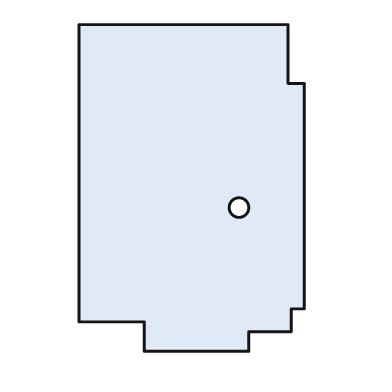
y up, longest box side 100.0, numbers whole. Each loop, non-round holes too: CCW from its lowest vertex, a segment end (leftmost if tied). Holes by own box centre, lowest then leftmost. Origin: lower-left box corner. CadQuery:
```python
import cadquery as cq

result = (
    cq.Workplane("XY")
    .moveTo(20.0, 0.0)
    .lineTo(52.0, 0.0)
    .lineTo(52.0, 6.0)
    .lineTo(65.0, 6.0)
    .lineTo(65.0, 13.0)
    .lineTo(69.0, 13.0)
    .lineTo(69.0, 82.0)
    .lineTo(64.0, 82.0)
    .lineTo(64.0, 100.0)
    .lineTo(0.0, 100.0)
    .lineTo(0.0, 9.0)
    .lineTo(20.0, 9.0)
    .close()
    .moveTo(49.0, 44.0)
    .circle(3.0)
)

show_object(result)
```